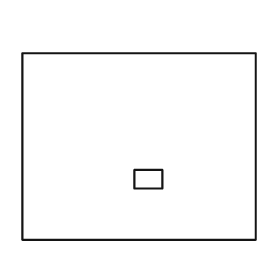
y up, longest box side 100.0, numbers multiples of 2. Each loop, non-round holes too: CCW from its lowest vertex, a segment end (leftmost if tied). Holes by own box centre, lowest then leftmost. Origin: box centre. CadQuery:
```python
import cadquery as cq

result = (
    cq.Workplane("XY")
    .moveTo(-50.0, -40.0)
    .lineTo(50.0, -40.0)
    .lineTo(50.0, 40.0)
    .lineTo(-50.0, 40.0)
    .close()
    .moveTo(-2.0, -18.0)
    .lineTo(10.0, -18.0)
    .lineTo(10.0, -10.0)
    .lineTo(-2.0, -10.0)
    .close()
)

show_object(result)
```